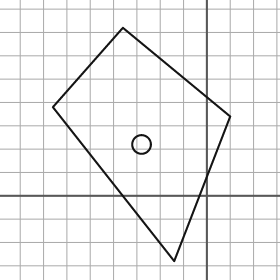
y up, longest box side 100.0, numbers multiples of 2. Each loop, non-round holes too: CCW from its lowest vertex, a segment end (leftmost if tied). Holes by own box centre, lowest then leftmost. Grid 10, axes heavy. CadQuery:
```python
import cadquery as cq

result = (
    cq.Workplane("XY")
    .moveTo(-14.0, -28.0)
    .lineTo(10.0, 34.0)
    .lineTo(-36.0, 72.0)
    .lineTo(-66.0, 38.0)
    .close()
    .moveTo(-28.0, 22.0)
    .circle(4.0)
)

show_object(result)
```